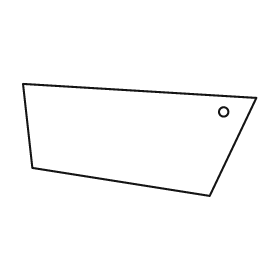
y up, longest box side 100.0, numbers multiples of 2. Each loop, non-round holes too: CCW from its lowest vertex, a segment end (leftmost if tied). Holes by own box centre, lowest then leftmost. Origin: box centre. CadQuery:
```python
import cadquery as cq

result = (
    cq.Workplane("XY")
    .moveTo(30.0, -24.0)
    .lineTo(50.0, 18.0)
    .lineTo(-50.0, 24.0)
    .lineTo(-46.0, -12.0)
    .close()
    .moveTo(36.0, 12.0)
    .circle(2.0)
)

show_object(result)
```